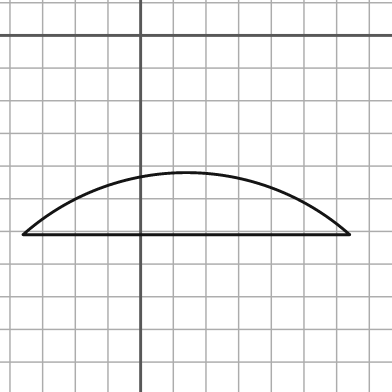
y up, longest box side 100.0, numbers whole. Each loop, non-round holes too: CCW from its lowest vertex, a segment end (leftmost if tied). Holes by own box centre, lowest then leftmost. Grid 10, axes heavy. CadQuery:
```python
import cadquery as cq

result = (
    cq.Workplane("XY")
    .moveTo(-36.0, -61.0)
    .lineTo(64.0, -61.0)
    .threePointArc((14.0, -42.0), (-36.0, -61.0))
    .close()
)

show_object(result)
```